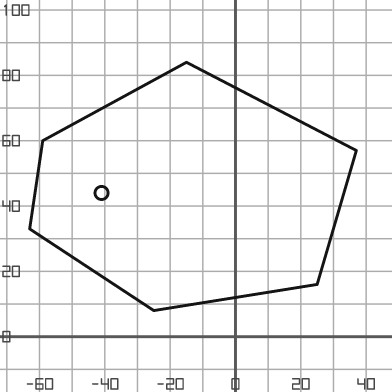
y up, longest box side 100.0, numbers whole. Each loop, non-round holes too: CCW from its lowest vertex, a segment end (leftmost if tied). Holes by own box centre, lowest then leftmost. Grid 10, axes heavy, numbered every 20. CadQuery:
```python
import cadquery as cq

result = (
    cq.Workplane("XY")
    .moveTo(-25.0, 8.0)
    .lineTo(25.0, 16.0)
    .lineTo(37.0, 57.0)
    .lineTo(-15.0, 84.0)
    .lineTo(-59.0, 60.0)
    .lineTo(-63.0, 33.0)
    .close()
    .moveTo(-41.0, 44.0)
    .circle(2.0)
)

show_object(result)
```